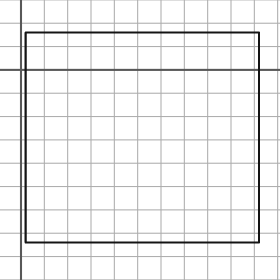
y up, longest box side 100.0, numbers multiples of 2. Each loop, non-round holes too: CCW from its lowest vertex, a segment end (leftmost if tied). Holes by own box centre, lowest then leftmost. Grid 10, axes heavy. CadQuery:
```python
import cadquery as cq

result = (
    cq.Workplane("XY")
    .moveTo(2.0, -74.0)
    .lineTo(102.0, -74.0)
    .lineTo(102.0, 16.0)
    .lineTo(2.0, 16.0)
    .close()
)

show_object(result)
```